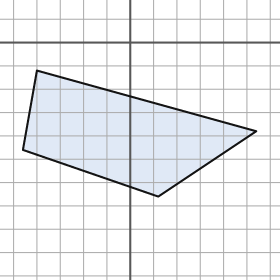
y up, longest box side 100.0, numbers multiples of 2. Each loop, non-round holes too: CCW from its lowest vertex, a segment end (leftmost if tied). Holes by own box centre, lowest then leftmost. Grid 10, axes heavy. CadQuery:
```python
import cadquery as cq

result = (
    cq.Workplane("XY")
    .moveTo(12.0, -66.0)
    .lineTo(54.0, -38.0)
    .lineTo(-40.0, -12.0)
    .lineTo(-46.0, -46.0)
    .close()
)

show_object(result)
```